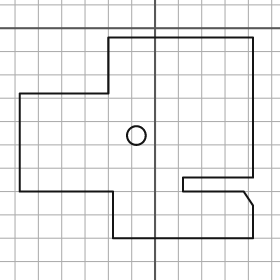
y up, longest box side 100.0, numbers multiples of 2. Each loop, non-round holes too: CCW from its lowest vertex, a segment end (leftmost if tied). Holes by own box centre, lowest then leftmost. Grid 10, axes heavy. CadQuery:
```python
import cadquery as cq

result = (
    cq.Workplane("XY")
    .moveTo(-18.0, -90.0)
    .lineTo(42.0, -90.0)
    .lineTo(42.0, -76.0)
    .lineTo(38.0, -70.0)
    .lineTo(12.0, -70.0)
    .lineTo(12.0, -64.0)
    .lineTo(42.0, -64.0)
    .lineTo(42.0, -4.0)
    .lineTo(-20.0, -4.0)
    .lineTo(-20.0, -28.0)
    .lineTo(-58.0, -28.0)
    .lineTo(-58.0, -70.0)
    .lineTo(-18.0, -70.0)
    .close()
    .moveTo(-8.0, -46.0)
    .circle(4.0)
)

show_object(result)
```